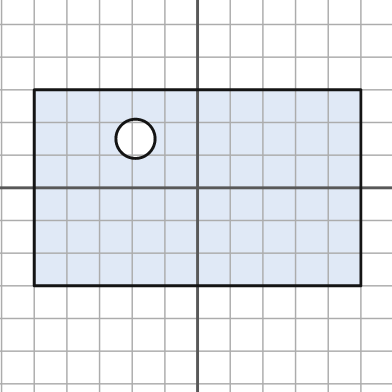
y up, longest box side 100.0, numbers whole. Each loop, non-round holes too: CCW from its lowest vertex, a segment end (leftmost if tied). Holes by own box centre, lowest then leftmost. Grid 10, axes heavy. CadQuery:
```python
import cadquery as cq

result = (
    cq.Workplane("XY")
    .moveTo(-50.0, -30.0)
    .lineTo(50.0, -30.0)
    .lineTo(50.0, 30.0)
    .lineTo(-50.0, 30.0)
    .close()
    .moveTo(-19.0, 15.0)
    .circle(6.0)
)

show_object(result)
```